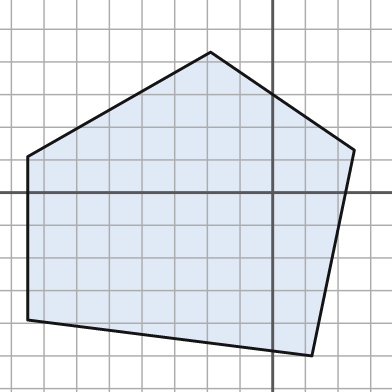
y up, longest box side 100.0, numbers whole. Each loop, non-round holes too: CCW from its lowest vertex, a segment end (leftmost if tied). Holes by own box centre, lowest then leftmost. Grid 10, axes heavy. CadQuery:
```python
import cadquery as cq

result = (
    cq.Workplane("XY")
    .moveTo(12.0, -50.0)
    .lineTo(25.0, 13.0)
    .lineTo(-19.0, 43.0)
    .lineTo(-75.0, 11.0)
    .lineTo(-75.0, -39.0)
    .close()
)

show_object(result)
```